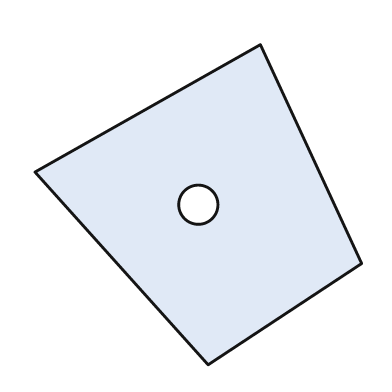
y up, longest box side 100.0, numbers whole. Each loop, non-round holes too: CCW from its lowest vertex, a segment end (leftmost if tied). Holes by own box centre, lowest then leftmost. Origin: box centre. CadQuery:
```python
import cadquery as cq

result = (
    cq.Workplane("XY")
    .moveTo(3.0, -49.0)
    .lineTo(50.0, -18.0)
    .lineTo(19.0, 49.0)
    .lineTo(-50.0, 10.0)
    .close()
    .moveTo(0.0, 0.0)
    .circle(6.0)
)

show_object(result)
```